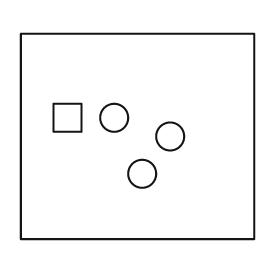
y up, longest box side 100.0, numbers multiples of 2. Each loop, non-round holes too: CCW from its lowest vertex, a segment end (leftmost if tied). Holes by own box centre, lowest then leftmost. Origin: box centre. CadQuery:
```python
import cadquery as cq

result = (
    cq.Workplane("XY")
    .moveTo(-50.0, -44.0)
    .lineTo(50.0, -44.0)
    .lineTo(50.0, 44.0)
    .lineTo(-50.0, 44.0)
    .close()
    .moveTo(2.0, -16.0)
    .circle(6.0)
    .moveTo(14.0, 0.0)
    .circle(6.0)
    .moveTo(-36.0, 2.0)
    .lineTo(-24.0, 2.0)
    .lineTo(-24.0, 14.0)
    .lineTo(-36.0, 14.0)
    .close()
    .moveTo(-10.0, 8.0)
    .circle(6.0)
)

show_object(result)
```